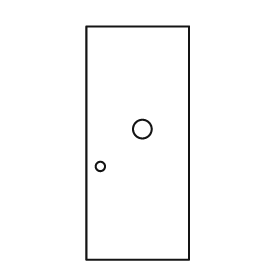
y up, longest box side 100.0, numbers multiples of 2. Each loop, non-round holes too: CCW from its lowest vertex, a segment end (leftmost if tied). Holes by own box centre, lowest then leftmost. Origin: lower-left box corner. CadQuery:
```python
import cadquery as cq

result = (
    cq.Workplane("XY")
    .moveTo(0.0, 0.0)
    .lineTo(44.0, 0.0)
    .lineTo(44.0, 100.0)
    .lineTo(0.0, 100.0)
    .close()
    .moveTo(6.0, 40.0)
    .circle(2.0)
    .moveTo(24.0, 56.0)
    .circle(4.0)
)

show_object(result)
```